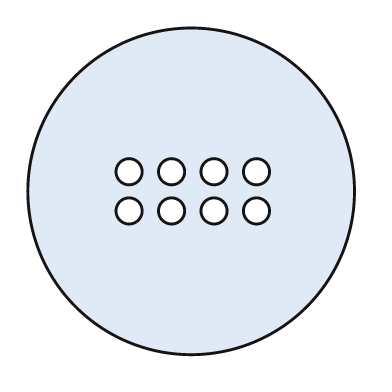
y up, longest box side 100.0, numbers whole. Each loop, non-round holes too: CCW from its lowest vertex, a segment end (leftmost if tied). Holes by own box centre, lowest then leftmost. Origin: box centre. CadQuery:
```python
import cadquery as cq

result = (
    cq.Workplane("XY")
    .moveTo(0.0, 0.0)
    .circle(50.0)
    .moveTo(-19.0, -6.0)
    .circle(4.0)
    .moveTo(-6.0, -6.0)
    .circle(4.0)
    .moveTo(7.0, -6.0)
    .circle(4.0)
    .moveTo(20.0, -6.0)
    .circle(4.0)
    .moveTo(-19.0, 6.0)
    .circle(4.0)
    .moveTo(-6.0, 6.0)
    .circle(4.0)
    .moveTo(7.0, 6.0)
    .circle(4.0)
    .moveTo(20.0, 6.0)
    .circle(4.0)
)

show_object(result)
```